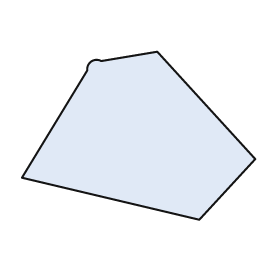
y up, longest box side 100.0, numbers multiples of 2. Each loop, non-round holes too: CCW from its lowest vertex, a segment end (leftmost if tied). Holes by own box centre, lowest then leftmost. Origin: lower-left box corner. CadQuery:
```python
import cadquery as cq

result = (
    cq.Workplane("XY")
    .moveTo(76.0, 0.0)
    .lineTo(100.0, 26.0)
    .lineTo(58.0, 72.0)
    .lineTo(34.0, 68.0)
    .threePointArc((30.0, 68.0), (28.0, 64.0))
    .lineTo(0.0, 18.0)
    .close()
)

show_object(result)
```